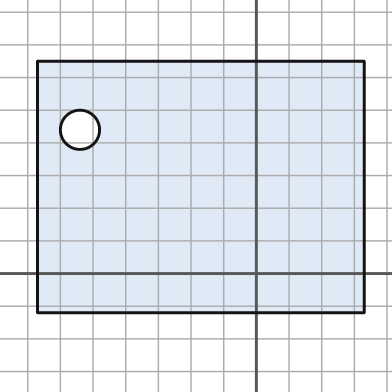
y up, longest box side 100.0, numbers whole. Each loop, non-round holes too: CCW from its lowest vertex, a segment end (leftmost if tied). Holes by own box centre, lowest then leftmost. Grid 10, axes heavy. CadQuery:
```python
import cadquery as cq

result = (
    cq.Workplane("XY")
    .moveTo(-67.0, -12.0)
    .lineTo(33.0, -12.0)
    .lineTo(33.0, 65.0)
    .lineTo(-67.0, 65.0)
    .close()
    .moveTo(-54.0, 44.0)
    .circle(6.0)
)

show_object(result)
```